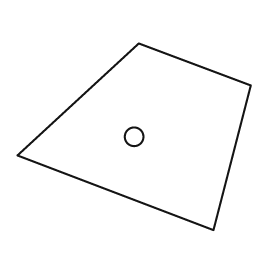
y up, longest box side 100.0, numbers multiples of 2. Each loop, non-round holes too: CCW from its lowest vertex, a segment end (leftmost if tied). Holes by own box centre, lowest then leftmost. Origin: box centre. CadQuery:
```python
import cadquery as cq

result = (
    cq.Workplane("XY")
    .moveTo(34.0, -40.0)
    .lineTo(50.0, 22.0)
    .lineTo(2.0, 40.0)
    .lineTo(-50.0, -8.0)
    .close()
    .moveTo(0.0, 0.0)
    .circle(4.0)
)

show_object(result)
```